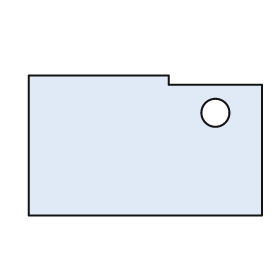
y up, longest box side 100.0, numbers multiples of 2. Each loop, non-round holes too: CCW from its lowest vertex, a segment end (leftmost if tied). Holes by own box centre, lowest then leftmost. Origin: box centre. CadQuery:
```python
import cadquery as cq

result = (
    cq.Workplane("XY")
    .moveTo(-50.0, -30.0)
    .lineTo(50.0, -30.0)
    .lineTo(50.0, 26.0)
    .lineTo(10.0, 26.0)
    .lineTo(10.0, 30.0)
    .lineTo(-50.0, 30.0)
    .close()
    .moveTo(30.0, 14.0)
    .circle(6.0)
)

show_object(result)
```